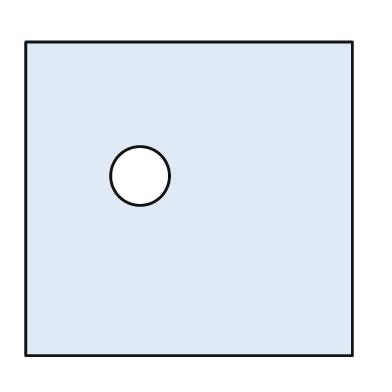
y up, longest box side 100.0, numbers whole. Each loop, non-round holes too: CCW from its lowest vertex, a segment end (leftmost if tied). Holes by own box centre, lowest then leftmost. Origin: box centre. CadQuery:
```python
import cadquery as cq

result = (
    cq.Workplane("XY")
    .moveTo(-50.0, -48.0)
    .lineTo(50.0, -48.0)
    .lineTo(50.0, 48.0)
    .lineTo(-50.0, 48.0)
    .close()
    .moveTo(-15.0, 7.0)
    .circle(9.0)
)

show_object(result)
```